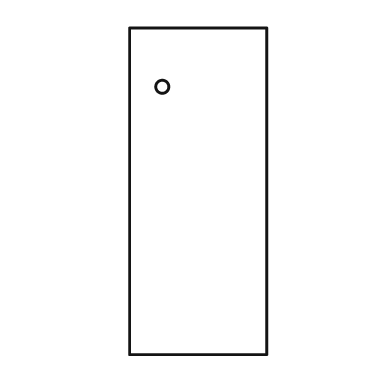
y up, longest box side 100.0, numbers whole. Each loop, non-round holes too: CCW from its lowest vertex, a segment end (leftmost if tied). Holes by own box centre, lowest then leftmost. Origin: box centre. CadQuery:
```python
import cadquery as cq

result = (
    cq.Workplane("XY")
    .moveTo(-21.0, -50.0)
    .lineTo(21.0, -50.0)
    .lineTo(21.0, 50.0)
    .lineTo(-21.0, 50.0)
    .close()
    .moveTo(-11.0, 32.0)
    .circle(2.0)
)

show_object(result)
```